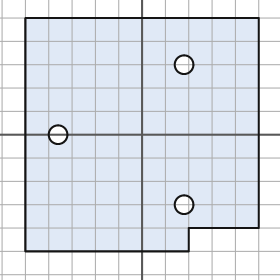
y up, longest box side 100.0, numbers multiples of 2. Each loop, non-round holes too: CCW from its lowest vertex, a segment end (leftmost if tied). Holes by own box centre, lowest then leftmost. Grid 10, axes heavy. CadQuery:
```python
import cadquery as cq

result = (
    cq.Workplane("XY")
    .moveTo(-50.0, -50.0)
    .lineTo(20.0, -50.0)
    .lineTo(20.0, -40.0)
    .lineTo(50.0, -40.0)
    .lineTo(50.0, 50.0)
    .lineTo(-50.0, 50.0)
    .close()
    .moveTo(18.0, -30.0)
    .circle(4.0)
    .moveTo(-36.0, 0.0)
    .circle(4.0)
    .moveTo(18.0, 30.0)
    .circle(4.0)
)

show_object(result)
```